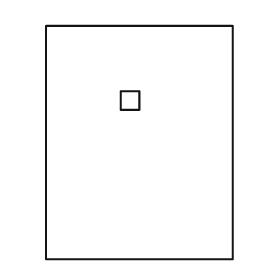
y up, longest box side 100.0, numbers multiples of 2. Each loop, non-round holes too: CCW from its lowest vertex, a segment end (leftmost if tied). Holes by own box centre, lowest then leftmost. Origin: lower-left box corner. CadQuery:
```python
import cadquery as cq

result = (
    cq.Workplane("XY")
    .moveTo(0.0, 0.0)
    .lineTo(80.0, 0.0)
    .lineTo(80.0, 100.0)
    .lineTo(0.0, 100.0)
    .close()
    .moveTo(32.0, 64.0)
    .lineTo(40.0, 64.0)
    .lineTo(40.0, 72.0)
    .lineTo(32.0, 72.0)
    .close()
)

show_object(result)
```